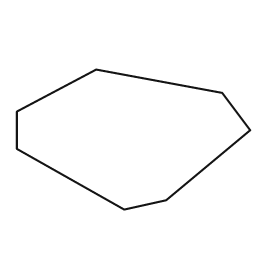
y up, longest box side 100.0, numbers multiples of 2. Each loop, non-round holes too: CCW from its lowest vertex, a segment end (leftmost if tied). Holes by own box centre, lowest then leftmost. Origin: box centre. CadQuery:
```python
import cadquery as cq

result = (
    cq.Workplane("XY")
    .moveTo(-4.0, -30.0)
    .lineTo(14.0, -26.0)
    .lineTo(50.0, 4.0)
    .lineTo(38.0, 20.0)
    .lineTo(-16.0, 30.0)
    .lineTo(-50.0, 12.0)
    .lineTo(-50.0, -4.0)
    .close()
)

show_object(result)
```